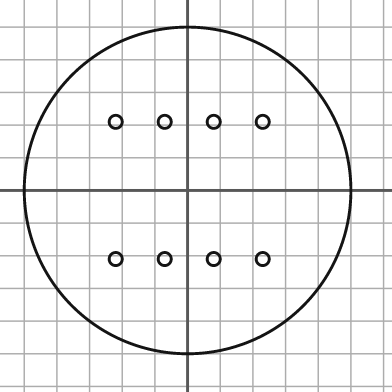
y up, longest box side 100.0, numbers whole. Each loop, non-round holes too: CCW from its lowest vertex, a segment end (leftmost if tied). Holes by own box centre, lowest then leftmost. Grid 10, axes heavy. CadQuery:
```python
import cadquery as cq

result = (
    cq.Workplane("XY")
    .moveTo(0.0, 0.0)
    .circle(50.0)
    .moveTo(-22.0, -21.0)
    .circle(2.0)
    .moveTo(-7.0, -21.0)
    .circle(2.0)
    .moveTo(8.0, -21.0)
    .circle(2.0)
    .moveTo(23.0, -21.0)
    .circle(2.0)
    .moveTo(-22.0, 21.0)
    .circle(2.0)
    .moveTo(-7.0, 21.0)
    .circle(2.0)
    .moveTo(8.0, 21.0)
    .circle(2.0)
    .moveTo(23.0, 21.0)
    .circle(2.0)
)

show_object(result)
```